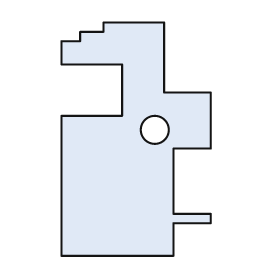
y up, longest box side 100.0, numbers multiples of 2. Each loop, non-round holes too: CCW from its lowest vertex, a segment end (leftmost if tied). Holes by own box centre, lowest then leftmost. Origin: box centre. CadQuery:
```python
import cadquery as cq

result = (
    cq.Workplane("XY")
    .moveTo(-32.0, -50.0)
    .lineTo(16.0, -50.0)
    .lineTo(16.0, -36.0)
    .lineTo(32.0, -36.0)
    .lineTo(32.0, -32.0)
    .lineTo(16.0, -32.0)
    .lineTo(16.0, -4.0)
    .lineTo(32.0, -4.0)
    .lineTo(32.0, 20.0)
    .lineTo(12.0, 20.0)
    .lineTo(12.0, 50.0)
    .lineTo(-14.0, 50.0)
    .lineTo(-14.0, 46.0)
    .lineTo(-24.0, 46.0)
    .lineTo(-24.0, 42.0)
    .lineTo(-32.0, 42.0)
    .lineTo(-32.0, 32.0)
    .lineTo(-6.0, 32.0)
    .lineTo(-6.0, 10.0)
    .lineTo(-32.0, 10.0)
    .close()
    .moveTo(8.0, 4.0)
    .circle(6.0)
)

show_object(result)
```